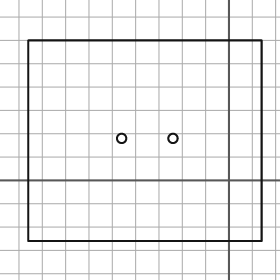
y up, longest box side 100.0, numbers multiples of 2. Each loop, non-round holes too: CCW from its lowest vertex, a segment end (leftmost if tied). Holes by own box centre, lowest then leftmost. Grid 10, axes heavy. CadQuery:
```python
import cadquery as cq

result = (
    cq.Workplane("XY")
    .moveTo(-86.0, -26.0)
    .lineTo(14.0, -26.0)
    .lineTo(14.0, 60.0)
    .lineTo(-86.0, 60.0)
    .close()
    .moveTo(-46.0, 18.0)
    .circle(2.0)
    .moveTo(-24.0, 18.0)
    .circle(2.0)
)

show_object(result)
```